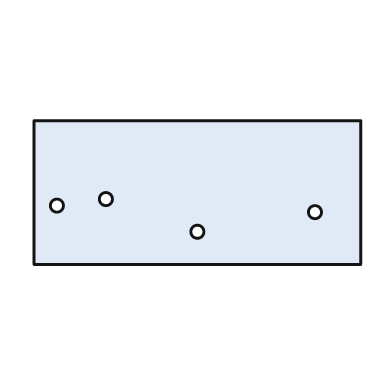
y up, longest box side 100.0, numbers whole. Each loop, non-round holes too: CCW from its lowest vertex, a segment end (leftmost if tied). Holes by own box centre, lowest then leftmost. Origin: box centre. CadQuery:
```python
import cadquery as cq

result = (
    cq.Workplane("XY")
    .moveTo(-50.0, -22.0)
    .lineTo(50.0, -22.0)
    .lineTo(50.0, 22.0)
    .lineTo(-50.0, 22.0)
    .close()
    .moveTo(0.0, -12.0)
    .circle(2.0)
    .moveTo(36.0, -6.0)
    .circle(2.0)
    .moveTo(-43.0, -4.0)
    .circle(2.0)
    .moveTo(-28.0, -2.0)
    .circle(2.0)
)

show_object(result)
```